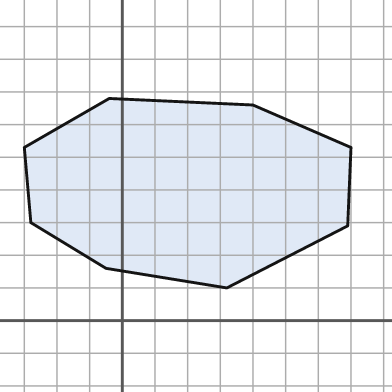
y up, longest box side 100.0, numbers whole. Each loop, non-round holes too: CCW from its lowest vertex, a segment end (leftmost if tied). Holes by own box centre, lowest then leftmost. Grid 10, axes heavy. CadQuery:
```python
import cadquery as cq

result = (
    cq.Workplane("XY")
    .moveTo(32.0, 10.0)
    .lineTo(69.0, 29.0)
    .lineTo(70.0, 53.0)
    .lineTo(40.0, 66.0)
    .lineTo(-4.0, 68.0)
    .lineTo(-30.0, 53.0)
    .lineTo(-28.0, 30.0)
    .lineTo(-5.0, 16.0)
    .close()
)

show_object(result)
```